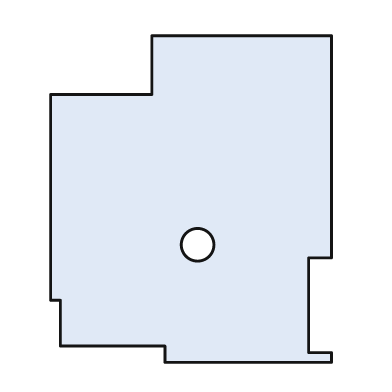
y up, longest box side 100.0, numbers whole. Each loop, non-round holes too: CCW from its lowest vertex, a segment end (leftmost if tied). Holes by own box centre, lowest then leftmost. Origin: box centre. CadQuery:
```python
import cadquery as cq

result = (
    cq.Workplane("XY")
    .moveTo(-8.0, -50.0)
    .lineTo(43.0, -50.0)
    .lineTo(43.0, -47.0)
    .lineTo(36.0, -47.0)
    .lineTo(36.0, -18.0)
    .lineTo(43.0, -18.0)
    .lineTo(43.0, 50.0)
    .lineTo(-12.0, 50.0)
    .lineTo(-12.0, 32.0)
    .lineTo(-43.0, 32.0)
    .lineTo(-43.0, -31.0)
    .lineTo(-40.0, -31.0)
    .lineTo(-40.0, -45.0)
    .lineTo(-8.0, -45.0)
    .close()
    .moveTo(2.0, -14.0)
    .circle(5.0)
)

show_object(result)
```